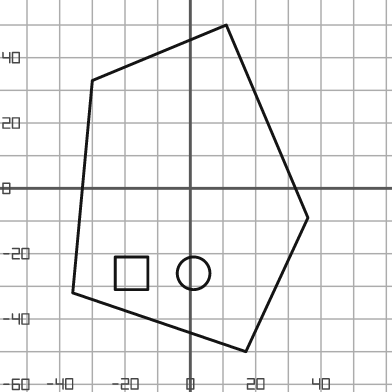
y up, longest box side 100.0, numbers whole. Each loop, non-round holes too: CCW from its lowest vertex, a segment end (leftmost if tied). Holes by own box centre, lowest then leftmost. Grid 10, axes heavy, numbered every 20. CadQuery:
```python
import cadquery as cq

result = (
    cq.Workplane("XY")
    .moveTo(17.0, -50.0)
    .lineTo(36.0, -9.0)
    .lineTo(11.0, 50.0)
    .lineTo(-30.0, 33.0)
    .lineTo(-36.0, -32.0)
    .close()
    .moveTo(-23.0, -31.0)
    .lineTo(-13.0, -31.0)
    .lineTo(-13.0, -21.0)
    .lineTo(-23.0, -21.0)
    .close()
    .moveTo(1.0, -26.0)
    .circle(5.0)
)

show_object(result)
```